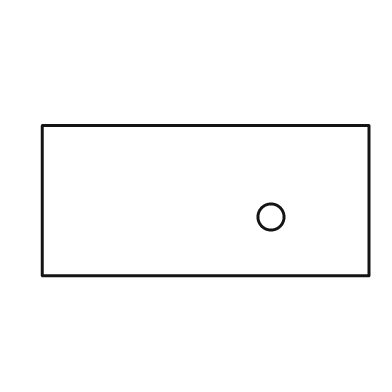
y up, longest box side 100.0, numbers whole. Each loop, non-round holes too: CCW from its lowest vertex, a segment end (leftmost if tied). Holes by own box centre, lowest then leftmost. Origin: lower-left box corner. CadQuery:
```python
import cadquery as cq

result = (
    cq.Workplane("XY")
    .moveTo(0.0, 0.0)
    .lineTo(100.0, 0.0)
    .lineTo(100.0, 46.0)
    .lineTo(0.0, 46.0)
    .close()
    .moveTo(70.0, 18.0)
    .circle(4.0)
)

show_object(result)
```